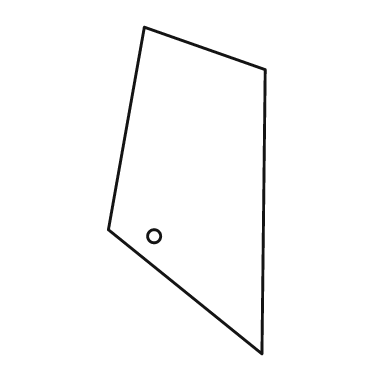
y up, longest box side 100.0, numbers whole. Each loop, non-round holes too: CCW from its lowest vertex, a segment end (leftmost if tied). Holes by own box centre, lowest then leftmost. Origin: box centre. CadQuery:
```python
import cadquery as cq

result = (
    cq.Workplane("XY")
    .moveTo(23.0, -50.0)
    .lineTo(24.0, 37.0)
    .lineTo(-13.0, 50.0)
    .lineTo(-24.0, -12.0)
    .close()
    .moveTo(-10.0, -14.0)
    .circle(2.0)
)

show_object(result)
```